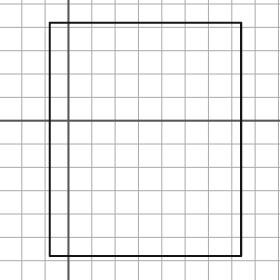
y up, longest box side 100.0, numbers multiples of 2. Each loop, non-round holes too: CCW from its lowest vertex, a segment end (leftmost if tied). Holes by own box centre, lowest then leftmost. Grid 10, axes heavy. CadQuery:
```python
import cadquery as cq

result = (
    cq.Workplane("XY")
    .moveTo(-8.0, -58.0)
    .lineTo(74.0, -58.0)
    .lineTo(74.0, 42.0)
    .lineTo(-8.0, 42.0)
    .close()
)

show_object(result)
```